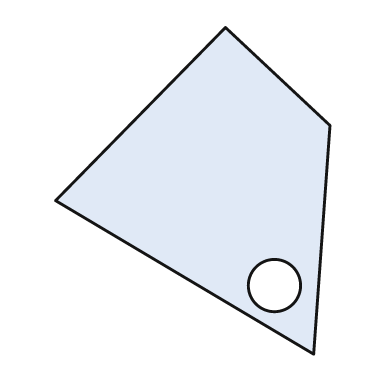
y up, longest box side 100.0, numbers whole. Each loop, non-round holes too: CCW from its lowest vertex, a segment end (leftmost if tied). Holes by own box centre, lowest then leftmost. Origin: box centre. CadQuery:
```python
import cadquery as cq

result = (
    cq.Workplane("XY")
    .moveTo(37.0, -50.0)
    .lineTo(42.0, 20.0)
    .lineTo(10.0, 50.0)
    .lineTo(-42.0, -3.0)
    .close()
    .moveTo(25.0, -29.0)
    .circle(8.0)
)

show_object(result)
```